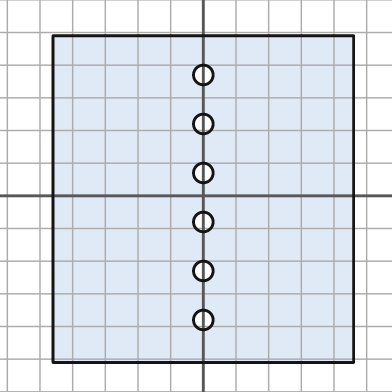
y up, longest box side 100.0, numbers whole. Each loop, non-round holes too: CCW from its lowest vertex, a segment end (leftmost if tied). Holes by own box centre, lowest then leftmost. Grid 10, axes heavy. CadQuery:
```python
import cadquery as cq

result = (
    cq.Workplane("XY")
    .moveTo(-46.0, -51.0)
    .lineTo(46.0, -51.0)
    .lineTo(46.0, 49.0)
    .lineTo(-46.0, 49.0)
    .close()
    .moveTo(0.0, -38.0)
    .circle(3.0)
    .moveTo(0.0, -23.0)
    .circle(3.0)
    .moveTo(0.0, -8.0)
    .circle(3.0)
    .moveTo(0.0, 7.0)
    .circle(3.0)
    .moveTo(0.0, 22.0)
    .circle(3.0)
    .moveTo(0.0, 37.0)
    .circle(3.0)
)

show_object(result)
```